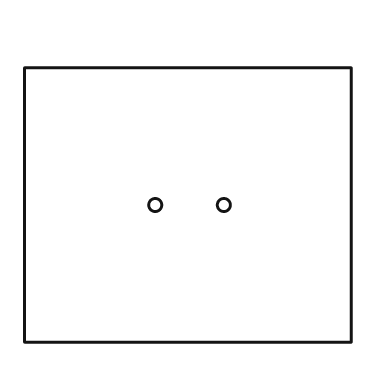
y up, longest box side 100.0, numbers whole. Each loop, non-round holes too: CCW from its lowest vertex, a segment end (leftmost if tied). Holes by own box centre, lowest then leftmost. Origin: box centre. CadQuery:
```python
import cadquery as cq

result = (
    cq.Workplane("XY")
    .moveTo(-50.0, -42.0)
    .lineTo(50.0, -42.0)
    .lineTo(50.0, 42.0)
    .lineTo(-50.0, 42.0)
    .close()
    .moveTo(-10.0, 0.0)
    .circle(2.0)
    .moveTo(11.0, 0.0)
    .circle(2.0)
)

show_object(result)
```